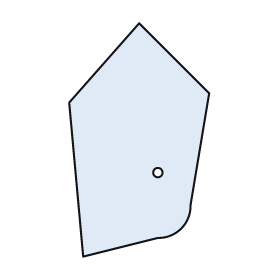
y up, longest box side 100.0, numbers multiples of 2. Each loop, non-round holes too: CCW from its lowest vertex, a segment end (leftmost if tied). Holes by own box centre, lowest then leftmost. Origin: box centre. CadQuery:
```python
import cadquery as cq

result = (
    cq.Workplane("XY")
    .moveTo(-24.0, -50.0)
    .lineTo(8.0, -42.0)
    .threePointArc((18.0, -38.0), (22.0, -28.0))
    .lineTo(30.0, 20.0)
    .lineTo(0.0, 50.0)
    .lineTo(-30.0, 16.0)
    .close()
    .moveTo(8.0, -14.0)
    .circle(2.0)
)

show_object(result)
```